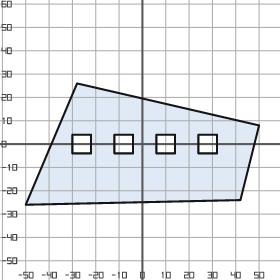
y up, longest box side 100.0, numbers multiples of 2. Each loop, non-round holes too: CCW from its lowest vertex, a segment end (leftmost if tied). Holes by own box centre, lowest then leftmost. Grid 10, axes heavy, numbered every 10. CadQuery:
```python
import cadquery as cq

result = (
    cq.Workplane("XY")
    .moveTo(-50.0, -26.0)
    .lineTo(42.0, -24.0)
    .lineTo(50.0, 8.0)
    .lineTo(-28.0, 26.0)
    .close()
    .moveTo(-30.0, -4.0)
    .lineTo(-22.0, -4.0)
    .lineTo(-22.0, 4.0)
    .lineTo(-30.0, 4.0)
    .close()
    .moveTo(-12.0, -4.0)
    .lineTo(-4.0, -4.0)
    .lineTo(-4.0, 4.0)
    .lineTo(-12.0, 4.0)
    .close()
    .moveTo(6.0, -4.0)
    .lineTo(14.0, -4.0)
    .lineTo(14.0, 4.0)
    .lineTo(6.0, 4.0)
    .close()
    .moveTo(24.0, -4.0)
    .lineTo(32.0, -4.0)
    .lineTo(32.0, 4.0)
    .lineTo(24.0, 4.0)
    .close()
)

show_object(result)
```